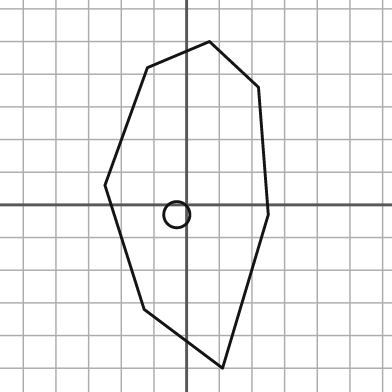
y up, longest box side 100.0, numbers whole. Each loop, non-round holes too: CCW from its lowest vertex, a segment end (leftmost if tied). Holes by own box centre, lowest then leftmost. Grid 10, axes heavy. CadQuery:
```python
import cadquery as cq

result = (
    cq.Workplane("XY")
    .moveTo(11.0, -50.0)
    .lineTo(25.0, -3.0)
    .lineTo(22.0, 36.0)
    .lineTo(7.0, 50.0)
    .lineTo(-12.0, 42.0)
    .lineTo(-25.0, 6.0)
    .lineTo(-13.0, -32.0)
    .close()
    .moveTo(-3.0, -3.0)
    .circle(4.0)
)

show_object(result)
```